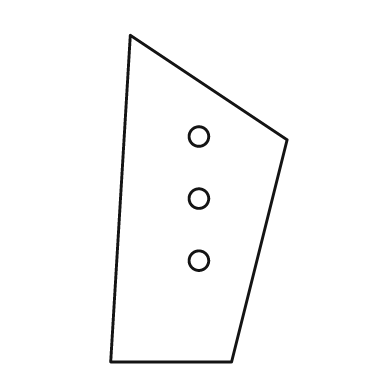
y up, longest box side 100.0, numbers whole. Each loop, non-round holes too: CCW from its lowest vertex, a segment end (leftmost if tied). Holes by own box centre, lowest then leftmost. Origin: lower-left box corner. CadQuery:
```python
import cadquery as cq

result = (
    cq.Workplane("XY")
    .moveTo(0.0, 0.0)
    .lineTo(37.0, 0.0)
    .lineTo(54.0, 68.0)
    .lineTo(6.0, 100.0)
    .close()
    .moveTo(27.0, 31.0)
    .circle(3.0)
    .moveTo(27.0, 50.0)
    .circle(3.0)
    .moveTo(27.0, 69.0)
    .circle(3.0)
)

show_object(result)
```